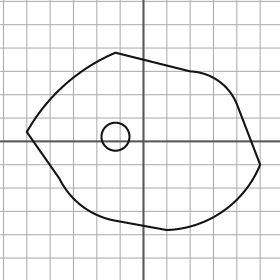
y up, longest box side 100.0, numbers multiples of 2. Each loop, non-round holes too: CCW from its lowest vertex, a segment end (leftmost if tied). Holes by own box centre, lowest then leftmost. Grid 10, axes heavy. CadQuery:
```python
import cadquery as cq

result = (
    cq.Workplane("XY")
    .moveTo(10.0, -38.0)
    .threePointArc((34.0, -30.0), (50.0, -10.0))
    .lineTo(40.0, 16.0)
    .threePointArc((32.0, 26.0), (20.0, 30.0))
    .lineTo(-12.0, 38.0)
    .threePointArc((-34.0, 24.0), (-50.0, 4.0))
    .lineTo(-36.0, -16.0)
    .threePointArc((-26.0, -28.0), (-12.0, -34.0))
    .close()
    .moveTo(-12.0, 2.0)
    .circle(6.0)
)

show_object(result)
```